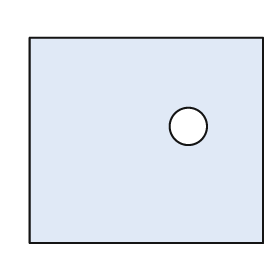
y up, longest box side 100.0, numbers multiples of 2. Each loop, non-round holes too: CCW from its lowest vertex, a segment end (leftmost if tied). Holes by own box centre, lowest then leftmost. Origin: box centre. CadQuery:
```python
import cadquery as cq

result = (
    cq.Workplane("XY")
    .moveTo(-50.0, -44.0)
    .lineTo(50.0, -44.0)
    .lineTo(50.0, 44.0)
    .lineTo(-50.0, 44.0)
    .close()
    .moveTo(18.0, 6.0)
    .circle(8.0)
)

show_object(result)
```